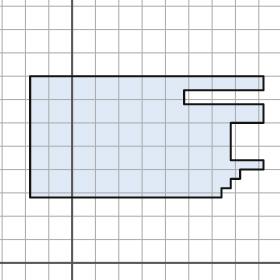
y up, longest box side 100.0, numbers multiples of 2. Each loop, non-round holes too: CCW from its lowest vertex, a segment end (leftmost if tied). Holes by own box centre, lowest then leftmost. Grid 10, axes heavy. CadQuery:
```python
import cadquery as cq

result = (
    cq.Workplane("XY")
    .moveTo(-18.0, 28.0)
    .lineTo(64.0, 28.0)
    .lineTo(64.0, 32.0)
    .lineTo(68.0, 32.0)
    .lineTo(68.0, 36.0)
    .lineTo(72.0, 36.0)
    .lineTo(72.0, 40.0)
    .lineTo(82.0, 40.0)
    .lineTo(82.0, 44.0)
    .lineTo(68.0, 44.0)
    .lineTo(68.0, 60.0)
    .lineTo(82.0, 60.0)
    .lineTo(82.0, 68.0)
    .lineTo(48.0, 68.0)
    .lineTo(48.0, 74.0)
    .lineTo(82.0, 74.0)
    .lineTo(82.0, 80.0)
    .lineTo(-18.0, 80.0)
    .close()
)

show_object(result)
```